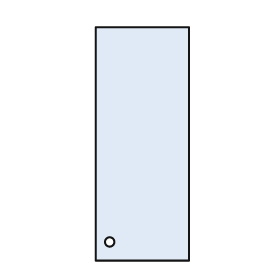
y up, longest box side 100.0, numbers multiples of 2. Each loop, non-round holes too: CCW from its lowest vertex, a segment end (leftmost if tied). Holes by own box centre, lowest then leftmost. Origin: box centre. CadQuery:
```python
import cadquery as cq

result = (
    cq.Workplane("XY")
    .moveTo(-20.0, -50.0)
    .lineTo(20.0, -50.0)
    .lineTo(20.0, 50.0)
    .lineTo(-20.0, 50.0)
    .close()
    .moveTo(-14.0, -42.0)
    .circle(2.0)
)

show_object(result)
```